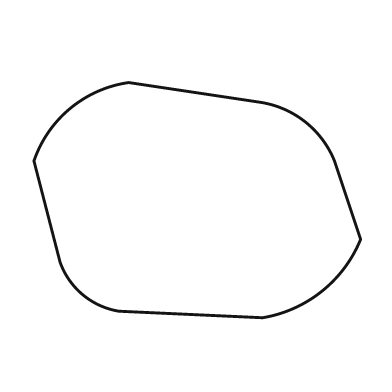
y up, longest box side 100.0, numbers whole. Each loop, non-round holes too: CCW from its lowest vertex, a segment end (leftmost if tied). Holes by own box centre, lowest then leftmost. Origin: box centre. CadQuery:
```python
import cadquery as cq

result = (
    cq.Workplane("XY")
    .moveTo(20.0, -36.0)
    .threePointArc((38.0, -28.0), (50.0, -12.0))
    .lineTo(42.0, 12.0)
    .threePointArc((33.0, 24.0), (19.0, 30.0))
    .lineTo(-21.0, 36.0)
    .threePointArc((-39.0, 28.0), (-50.0, 12.0))
    .lineTo(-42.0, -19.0)
    .threePointArc((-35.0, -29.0), (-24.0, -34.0))
    .close()
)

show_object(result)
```